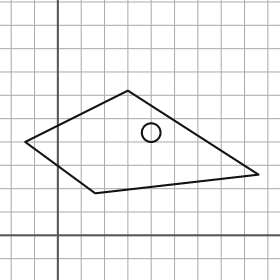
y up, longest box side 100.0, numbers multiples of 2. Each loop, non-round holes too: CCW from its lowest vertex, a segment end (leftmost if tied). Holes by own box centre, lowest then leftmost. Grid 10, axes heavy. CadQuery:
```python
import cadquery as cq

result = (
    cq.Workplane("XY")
    .moveTo(16.0, 18.0)
    .lineTo(86.0, 26.0)
    .lineTo(30.0, 62.0)
    .lineTo(-14.0, 40.0)
    .close()
    .moveTo(40.0, 44.0)
    .circle(4.0)
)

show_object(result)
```